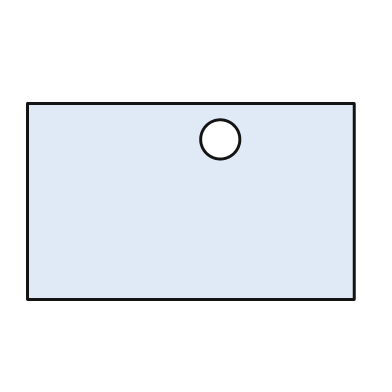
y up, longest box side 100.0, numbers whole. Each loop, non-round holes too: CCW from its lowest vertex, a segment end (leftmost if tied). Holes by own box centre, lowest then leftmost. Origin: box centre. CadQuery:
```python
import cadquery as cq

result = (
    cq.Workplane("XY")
    .moveTo(-50.0, -30.0)
    .lineTo(50.0, -30.0)
    .lineTo(50.0, 30.0)
    .lineTo(-50.0, 30.0)
    .close()
    .moveTo(9.0, 19.0)
    .circle(6.0)
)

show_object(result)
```